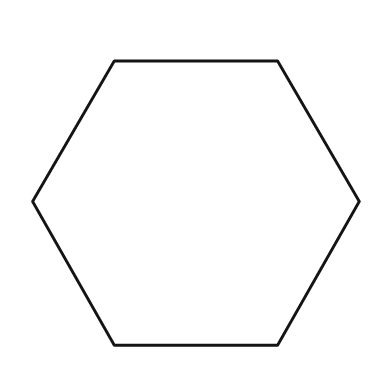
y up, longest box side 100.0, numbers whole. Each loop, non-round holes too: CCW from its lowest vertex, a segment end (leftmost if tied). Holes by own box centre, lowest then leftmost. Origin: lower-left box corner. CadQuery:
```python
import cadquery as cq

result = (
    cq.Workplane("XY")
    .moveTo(25.0, 0.0)
    .lineTo(75.0, 0.0)
    .lineTo(100.0, 44.0)
    .lineTo(75.0, 87.0)
    .lineTo(25.0, 87.0)
    .lineTo(0.0, 44.0)
    .close()
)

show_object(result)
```